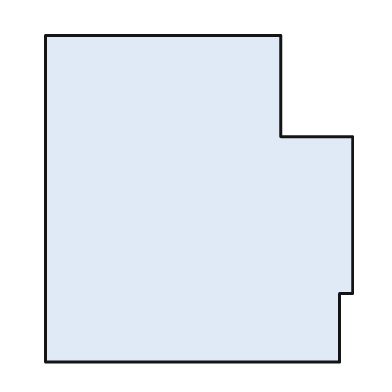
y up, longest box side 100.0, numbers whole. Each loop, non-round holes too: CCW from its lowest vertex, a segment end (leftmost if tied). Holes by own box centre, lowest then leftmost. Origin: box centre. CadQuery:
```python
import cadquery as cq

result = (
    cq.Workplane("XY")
    .moveTo(-47.0, -50.0)
    .lineTo(43.0, -50.0)
    .lineTo(43.0, -29.0)
    .lineTo(47.0, -29.0)
    .lineTo(47.0, 19.0)
    .lineTo(25.0, 19.0)
    .lineTo(25.0, 50.0)
    .lineTo(-47.0, 50.0)
    .close()
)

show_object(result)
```